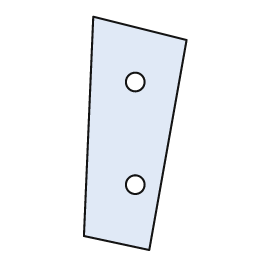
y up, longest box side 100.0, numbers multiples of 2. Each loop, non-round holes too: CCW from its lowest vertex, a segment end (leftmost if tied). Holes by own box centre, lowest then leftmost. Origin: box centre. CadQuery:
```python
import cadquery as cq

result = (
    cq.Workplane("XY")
    .moveTo(6.0, -50.0)
    .lineTo(22.0, 40.0)
    .lineTo(-18.0, 50.0)
    .lineTo(-22.0, -44.0)
    .close()
    .moveTo(0.0, -22.0)
    .circle(4.0)
    .moveTo(0.0, 22.0)
    .circle(4.0)
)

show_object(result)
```